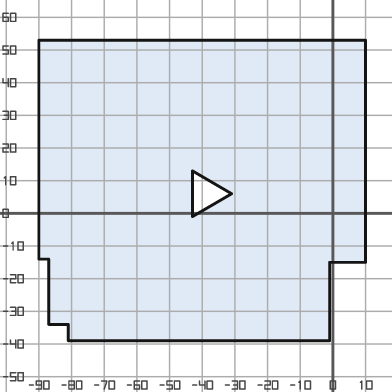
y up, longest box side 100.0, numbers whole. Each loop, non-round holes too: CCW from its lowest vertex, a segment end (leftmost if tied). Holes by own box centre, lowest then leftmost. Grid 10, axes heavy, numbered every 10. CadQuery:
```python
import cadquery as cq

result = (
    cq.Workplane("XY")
    .moveTo(-81.0, -39.0)
    .lineTo(-1.0, -39.0)
    .lineTo(-1.0, -15.0)
    .lineTo(10.0, -15.0)
    .lineTo(10.0, 53.0)
    .lineTo(-90.0, 53.0)
    .lineTo(-90.0, -14.0)
    .lineTo(-87.0, -14.0)
    .lineTo(-87.0, -34.0)
    .lineTo(-81.0, -34.0)
    .close()
    .moveTo(-43.0, -1.0)
    .lineTo(-31.0, 6.0)
    .lineTo(-43.0, 13.0)
    .close()
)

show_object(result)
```